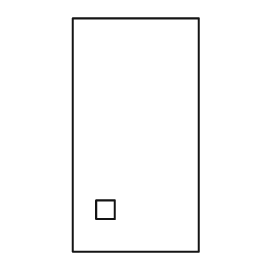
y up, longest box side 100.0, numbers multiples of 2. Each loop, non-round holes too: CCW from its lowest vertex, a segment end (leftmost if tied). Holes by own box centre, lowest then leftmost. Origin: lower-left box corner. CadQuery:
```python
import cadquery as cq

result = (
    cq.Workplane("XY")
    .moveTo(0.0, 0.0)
    .lineTo(54.0, 0.0)
    .lineTo(54.0, 100.0)
    .lineTo(0.0, 100.0)
    .close()
    .moveTo(10.0, 14.0)
    .lineTo(18.0, 14.0)
    .lineTo(18.0, 22.0)
    .lineTo(10.0, 22.0)
    .close()
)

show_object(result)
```